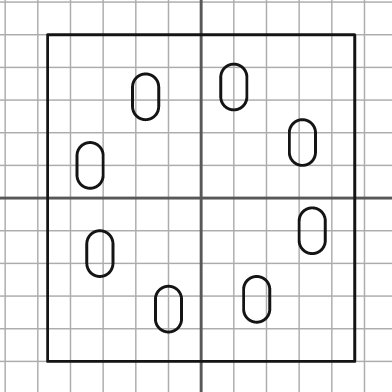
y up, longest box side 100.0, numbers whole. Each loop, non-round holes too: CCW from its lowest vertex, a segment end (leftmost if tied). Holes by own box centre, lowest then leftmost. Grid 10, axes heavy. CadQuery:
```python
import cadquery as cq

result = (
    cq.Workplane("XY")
    .moveTo(-47.0, -50.0)
    .lineTo(47.0, -50.0)
    .lineTo(47.0, 50.0)
    .lineTo(-47.0, 50.0)
    .close()
    .moveTo(-14.0, -37.0)
    .threePointArc((-10.0, -41.0), (-6.0, -37.0))
    .lineTo(-6.0, -31.0)
    .threePointArc((-10.0, -27.0), (-14.0, -31.0))
    .close()
    .moveTo(13.0, -34.0)
    .threePointArc((17.0, -38.0), (21.0, -34.0))
    .lineTo(21.0, -28.0)
    .threePointArc((17.0, -24.0), (13.0, -28.0))
    .close()
    .moveTo(-35.0, -20.0)
    .threePointArc((-31.0, -24.0), (-27.0, -20.0))
    .lineTo(-27.0, -14.0)
    .threePointArc((-31.0, -10.0), (-35.0, -14.0))
    .close()
    .moveTo(30.0, -13.0)
    .threePointArc((34.0, -17.0), (38.0, -13.0))
    .lineTo(38.0, -7.0)
    .threePointArc((34.0, -3.0), (30.0, -7.0))
    .close()
    .moveTo(-38.0, 7.0)
    .threePointArc((-34.0, 3.0), (-30.0, 7.0))
    .lineTo(-30.0, 13.0)
    .threePointArc((-34.0, 17.0), (-38.0, 13.0))
    .close()
    .moveTo(27.0, 14.0)
    .threePointArc((31.0, 10.0), (35.0, 14.0))
    .lineTo(35.0, 20.0)
    .threePointArc((31.0, 24.0), (27.0, 20.0))
    .close()
    .moveTo(-21.0, 28.0)
    .threePointArc((-17.0, 24.0), (-13.0, 28.0))
    .lineTo(-13.0, 34.0)
    .threePointArc((-17.0, 38.0), (-21.0, 34.0))
    .close()
    .moveTo(6.0, 31.0)
    .threePointArc((10.0, 27.0), (14.0, 31.0))
    .lineTo(14.0, 37.0)
    .threePointArc((10.0, 41.0), (6.0, 37.0))
    .close()
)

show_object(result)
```